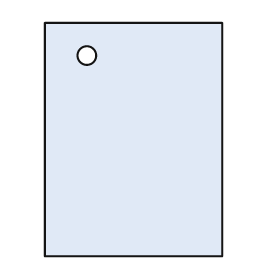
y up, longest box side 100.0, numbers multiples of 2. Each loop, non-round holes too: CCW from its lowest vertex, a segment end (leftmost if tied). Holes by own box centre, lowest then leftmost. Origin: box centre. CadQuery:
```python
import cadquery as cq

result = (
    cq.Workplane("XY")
    .moveTo(-38.0, -50.0)
    .lineTo(38.0, -50.0)
    .lineTo(38.0, 50.0)
    .lineTo(-38.0, 50.0)
    .close()
    .moveTo(-20.0, 36.0)
    .circle(4.0)
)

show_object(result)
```